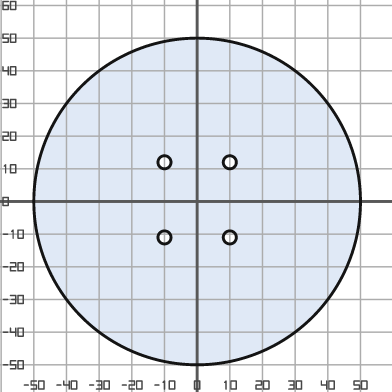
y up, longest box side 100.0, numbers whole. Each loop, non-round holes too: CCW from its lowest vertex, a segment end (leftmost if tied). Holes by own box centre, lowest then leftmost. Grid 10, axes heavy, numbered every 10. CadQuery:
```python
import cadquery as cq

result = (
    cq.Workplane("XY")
    .moveTo(0.0, 0.0)
    .circle(50.0)
    .moveTo(-10.0, -11.0)
    .circle(2.0)
    .moveTo(10.0, -11.0)
    .circle(2.0)
    .moveTo(-10.0, 12.0)
    .circle(2.0)
    .moveTo(10.0, 12.0)
    .circle(2.0)
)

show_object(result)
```